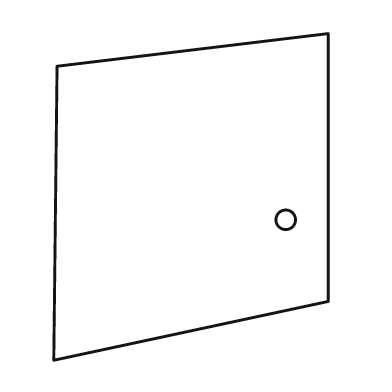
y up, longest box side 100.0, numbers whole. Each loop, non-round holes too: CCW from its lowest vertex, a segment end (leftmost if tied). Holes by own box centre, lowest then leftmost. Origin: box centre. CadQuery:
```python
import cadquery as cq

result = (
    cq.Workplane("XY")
    .moveTo(-42.0, -50.0)
    .lineTo(42.0, -32.0)
    .lineTo(42.0, 50.0)
    .lineTo(-41.0, 40.0)
    .close()
    .moveTo(29.0, -7.0)
    .circle(3.0)
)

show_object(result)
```